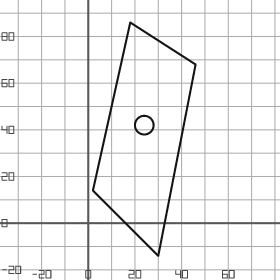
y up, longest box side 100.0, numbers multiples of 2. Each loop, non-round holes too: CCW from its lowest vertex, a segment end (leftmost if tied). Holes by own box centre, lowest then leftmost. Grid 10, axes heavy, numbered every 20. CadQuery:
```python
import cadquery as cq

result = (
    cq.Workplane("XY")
    .moveTo(30.0, -14.0)
    .lineTo(46.0, 68.0)
    .lineTo(18.0, 86.0)
    .lineTo(2.0, 14.0)
    .close()
    .moveTo(24.0, 42.0)
    .circle(4.0)
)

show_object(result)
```